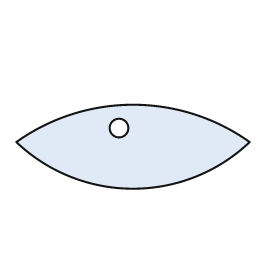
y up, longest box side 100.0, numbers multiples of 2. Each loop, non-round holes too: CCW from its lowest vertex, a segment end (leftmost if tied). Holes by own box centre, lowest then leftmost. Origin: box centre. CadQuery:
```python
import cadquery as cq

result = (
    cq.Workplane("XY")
    .moveTo(-50.0, 2.0)
    .threePointArc((0.0, -18.0), (50.0, 2.0))
    .threePointArc((0.0, 18.0), (-50.0, 2.0))
    .close()
    .moveTo(-6.0, 8.0)
    .circle(4.0)
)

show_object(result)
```